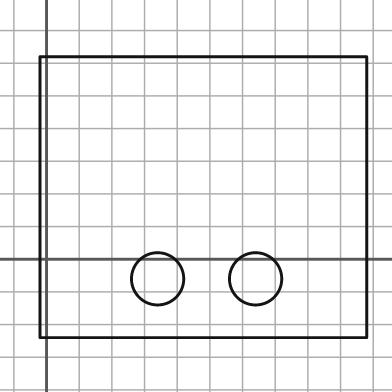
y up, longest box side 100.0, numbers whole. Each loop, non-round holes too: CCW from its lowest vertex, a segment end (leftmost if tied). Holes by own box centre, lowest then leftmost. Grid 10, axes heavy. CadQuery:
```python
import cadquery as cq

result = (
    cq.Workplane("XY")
    .moveTo(-2.0, -24.0)
    .lineTo(98.0, -24.0)
    .lineTo(98.0, 62.0)
    .lineTo(-2.0, 62.0)
    .close()
    .moveTo(34.0, -6.0)
    .circle(8.0)
    .moveTo(64.0, -6.0)
    .circle(8.0)
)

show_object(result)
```